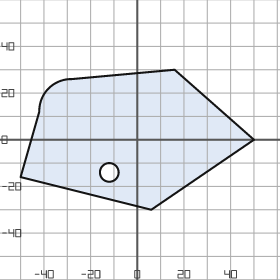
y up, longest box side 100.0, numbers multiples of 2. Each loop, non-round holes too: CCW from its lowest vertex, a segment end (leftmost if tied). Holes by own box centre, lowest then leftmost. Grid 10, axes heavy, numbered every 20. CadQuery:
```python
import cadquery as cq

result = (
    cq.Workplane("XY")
    .moveTo(6.0, -30.0)
    .lineTo(50.0, 0.0)
    .lineTo(16.0, 30.0)
    .lineTo(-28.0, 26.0)
    .threePointArc((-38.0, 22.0), (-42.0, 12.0))
    .lineTo(-50.0, -16.0)
    .close()
    .moveTo(-12.0, -14.0)
    .circle(4.0)
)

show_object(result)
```